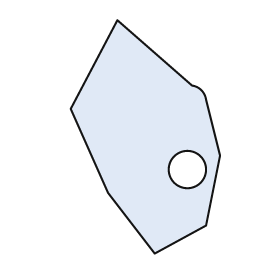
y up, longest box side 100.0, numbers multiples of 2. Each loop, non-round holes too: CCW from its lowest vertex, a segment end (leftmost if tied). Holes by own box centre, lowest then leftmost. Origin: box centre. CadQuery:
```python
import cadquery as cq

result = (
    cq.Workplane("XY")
    .moveTo(4.0, -50.0)
    .lineTo(26.0, -38.0)
    .lineTo(32.0, -8.0)
    .lineTo(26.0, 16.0)
    .threePointArc((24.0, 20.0), (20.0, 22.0))
    .lineTo(-12.0, 50.0)
    .lineTo(-32.0, 12.0)
    .lineTo(-16.0, -24.0)
    .close()
    .moveTo(18.0, -14.0)
    .circle(8.0)
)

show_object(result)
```